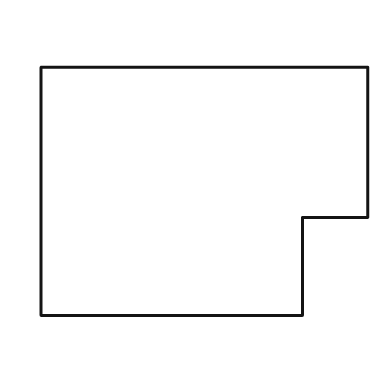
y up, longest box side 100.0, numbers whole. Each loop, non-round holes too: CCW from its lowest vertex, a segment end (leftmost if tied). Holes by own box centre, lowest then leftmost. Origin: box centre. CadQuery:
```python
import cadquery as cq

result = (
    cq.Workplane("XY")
    .moveTo(-50.0, -38.0)
    .lineTo(30.0, -38.0)
    .lineTo(30.0, -8.0)
    .lineTo(50.0, -8.0)
    .lineTo(50.0, 38.0)
    .lineTo(-50.0, 38.0)
    .close()
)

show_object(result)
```